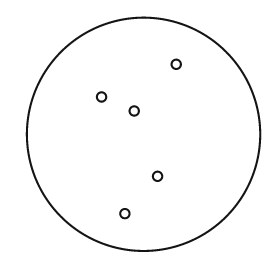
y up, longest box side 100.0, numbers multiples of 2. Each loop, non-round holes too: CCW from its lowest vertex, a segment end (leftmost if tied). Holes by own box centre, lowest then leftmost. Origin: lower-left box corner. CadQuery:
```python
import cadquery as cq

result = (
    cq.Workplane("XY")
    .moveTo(50.0, 50.0)
    .circle(50.0)
    .moveTo(42.0, 16.0)
    .circle(2.0)
    .moveTo(56.0, 32.0)
    .circle(2.0)
    .moveTo(46.0, 60.0)
    .circle(2.0)
    .moveTo(32.0, 66.0)
    .circle(2.0)
    .moveTo(64.0, 80.0)
    .circle(2.0)
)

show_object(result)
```